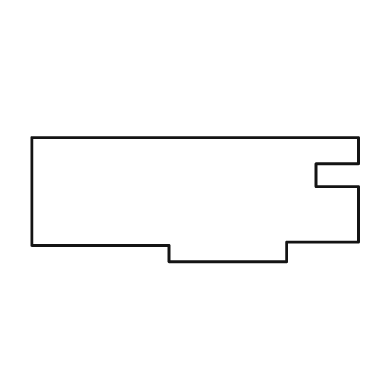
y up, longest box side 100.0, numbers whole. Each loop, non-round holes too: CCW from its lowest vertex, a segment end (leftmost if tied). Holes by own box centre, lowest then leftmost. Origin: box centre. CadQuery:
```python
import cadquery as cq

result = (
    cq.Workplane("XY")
    .moveTo(-8.0, -19.0)
    .lineTo(28.0, -19.0)
    .lineTo(28.0, -13.0)
    .lineTo(50.0, -13.0)
    .lineTo(50.0, 4.0)
    .lineTo(37.0, 4.0)
    .lineTo(37.0, 11.0)
    .lineTo(50.0, 11.0)
    .lineTo(50.0, 19.0)
    .lineTo(-50.0, 19.0)
    .lineTo(-50.0, -14.0)
    .lineTo(-8.0, -14.0)
    .close()
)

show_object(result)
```